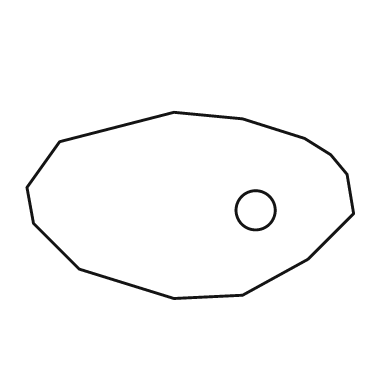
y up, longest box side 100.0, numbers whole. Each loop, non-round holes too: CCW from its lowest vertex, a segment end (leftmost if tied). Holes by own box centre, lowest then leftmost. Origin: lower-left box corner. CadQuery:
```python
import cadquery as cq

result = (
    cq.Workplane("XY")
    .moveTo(45.0, 0.0)
    .lineTo(66.0, 1.0)
    .lineTo(86.0, 12.0)
    .lineTo(100.0, 26.0)
    .lineTo(98.0, 38.0)
    .lineTo(93.0, 44.0)
    .lineTo(85.0, 49.0)
    .lineTo(66.0, 55.0)
    .lineTo(45.0, 57.0)
    .lineTo(10.0, 48.0)
    .lineTo(0.0, 34.0)
    .lineTo(2.0, 23.0)
    .lineTo(16.0, 9.0)
    .close()
    .moveTo(70.0, 27.0)
    .circle(6.0)
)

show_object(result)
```